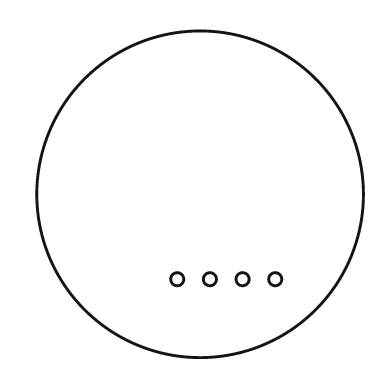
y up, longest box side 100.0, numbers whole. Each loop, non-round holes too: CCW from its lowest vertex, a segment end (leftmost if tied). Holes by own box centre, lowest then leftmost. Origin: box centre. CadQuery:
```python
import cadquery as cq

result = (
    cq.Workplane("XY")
    .moveTo(0.0, 0.0)
    .circle(50.0)
    .moveTo(-7.0, -26.0)
    .circle(2.0)
    .moveTo(3.0, -26.0)
    .circle(2.0)
    .moveTo(13.0, -26.0)
    .circle(2.0)
    .moveTo(23.0, -26.0)
    .circle(2.0)
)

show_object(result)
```